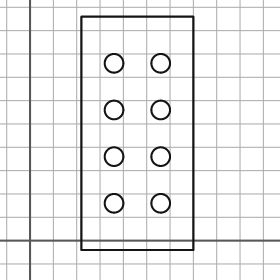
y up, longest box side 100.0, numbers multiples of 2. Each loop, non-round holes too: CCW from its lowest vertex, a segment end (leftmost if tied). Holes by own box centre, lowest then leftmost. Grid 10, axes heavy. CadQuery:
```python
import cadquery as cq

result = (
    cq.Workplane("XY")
    .moveTo(22.0, -4.0)
    .lineTo(70.0, -4.0)
    .lineTo(70.0, 96.0)
    .lineTo(22.0, 96.0)
    .close()
    .moveTo(36.0, 16.0)
    .circle(4.0)
    .moveTo(56.0, 16.0)
    .circle(4.0)
    .moveTo(36.0, 36.0)
    .circle(4.0)
    .moveTo(56.0, 36.0)
    .circle(4.0)
    .moveTo(36.0, 56.0)
    .circle(4.0)
    .moveTo(56.0, 56.0)
    .circle(4.0)
    .moveTo(36.0, 76.0)
    .circle(4.0)
    .moveTo(56.0, 76.0)
    .circle(4.0)
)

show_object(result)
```